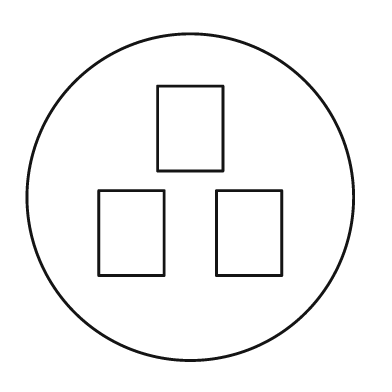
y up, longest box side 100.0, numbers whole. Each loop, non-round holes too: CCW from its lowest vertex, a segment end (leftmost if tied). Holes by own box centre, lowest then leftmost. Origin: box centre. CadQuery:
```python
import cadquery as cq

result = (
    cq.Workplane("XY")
    .moveTo(0.0, 0.0)
    .circle(50.0)
    .moveTo(-28.0, -24.0)
    .lineTo(-8.0, -24.0)
    .lineTo(-8.0, 2.0)
    .lineTo(-28.0, 2.0)
    .close()
    .moveTo(8.0, -24.0)
    .lineTo(28.0, -24.0)
    .lineTo(28.0, 2.0)
    .lineTo(8.0, 2.0)
    .close()
    .moveTo(-10.0, 8.0)
    .lineTo(10.0, 8.0)
    .lineTo(10.0, 34.0)
    .lineTo(-10.0, 34.0)
    .close()
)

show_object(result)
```